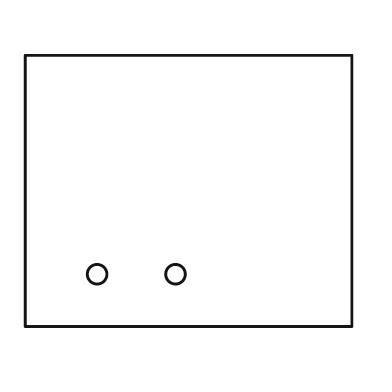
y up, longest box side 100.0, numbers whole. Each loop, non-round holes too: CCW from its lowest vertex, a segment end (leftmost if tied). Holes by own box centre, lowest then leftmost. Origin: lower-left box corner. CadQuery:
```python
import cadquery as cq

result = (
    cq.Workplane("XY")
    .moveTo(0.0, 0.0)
    .lineTo(100.0, 0.0)
    .lineTo(100.0, 83.0)
    .lineTo(0.0, 83.0)
    .close()
    .moveTo(22.0, 16.0)
    .circle(3.0)
    .moveTo(46.0, 16.0)
    .circle(3.0)
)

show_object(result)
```